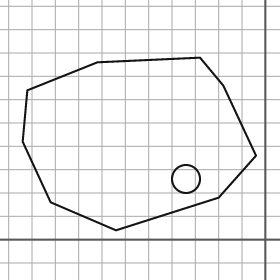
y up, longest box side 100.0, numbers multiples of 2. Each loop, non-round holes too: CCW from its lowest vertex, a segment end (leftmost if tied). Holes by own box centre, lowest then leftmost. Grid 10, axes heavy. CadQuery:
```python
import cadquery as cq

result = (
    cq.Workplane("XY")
    .moveTo(-64.0, 4.0)
    .lineTo(-20.0, 18.0)
    .lineTo(-4.0, 36.0)
    .lineTo(-18.0, 66.0)
    .lineTo(-28.0, 78.0)
    .lineTo(-72.0, 76.0)
    .lineTo(-102.0, 64.0)
    .lineTo(-104.0, 42.0)
    .lineTo(-92.0, 16.0)
    .close()
    .moveTo(-34.0, 26.0)
    .circle(6.0)
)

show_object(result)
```